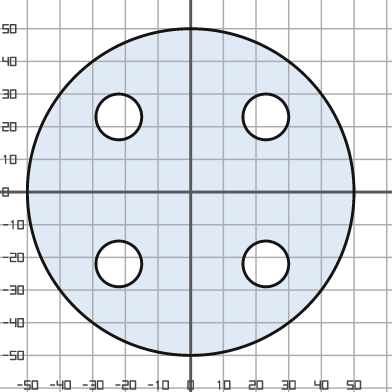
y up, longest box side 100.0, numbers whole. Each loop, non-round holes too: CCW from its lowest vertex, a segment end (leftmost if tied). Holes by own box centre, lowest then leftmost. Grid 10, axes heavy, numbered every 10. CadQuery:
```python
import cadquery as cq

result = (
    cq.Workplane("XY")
    .moveTo(0.0, 0.0)
    .circle(50.0)
    .moveTo(-22.0, -22.0)
    .circle(7.0)
    .moveTo(23.0, -22.0)
    .circle(7.0)
    .moveTo(-22.0, 23.0)
    .circle(7.0)
    .moveTo(23.0, 23.0)
    .circle(7.0)
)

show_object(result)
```